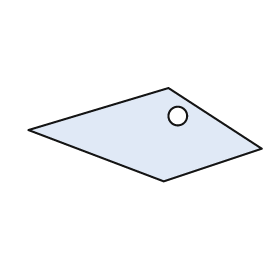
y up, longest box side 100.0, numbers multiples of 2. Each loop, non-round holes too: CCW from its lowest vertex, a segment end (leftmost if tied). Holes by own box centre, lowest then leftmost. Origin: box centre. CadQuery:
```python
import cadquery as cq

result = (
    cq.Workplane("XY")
    .moveTo(8.0, -20.0)
    .lineTo(50.0, -6.0)
    .lineTo(10.0, 20.0)
    .lineTo(-50.0, 2.0)
    .close()
    .moveTo(14.0, 8.0)
    .circle(4.0)
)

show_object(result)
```